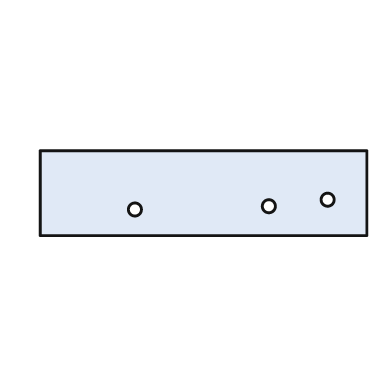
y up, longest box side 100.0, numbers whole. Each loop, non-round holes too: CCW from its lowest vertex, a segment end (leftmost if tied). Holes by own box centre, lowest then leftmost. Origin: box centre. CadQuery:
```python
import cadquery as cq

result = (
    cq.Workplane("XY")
    .moveTo(-50.0, -13.0)
    .lineTo(50.0, -13.0)
    .lineTo(50.0, 13.0)
    .lineTo(-50.0, 13.0)
    .close()
    .moveTo(-21.0, -5.0)
    .circle(2.0)
    .moveTo(20.0, -4.0)
    .circle(2.0)
    .moveTo(38.0, -2.0)
    .circle(2.0)
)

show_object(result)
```